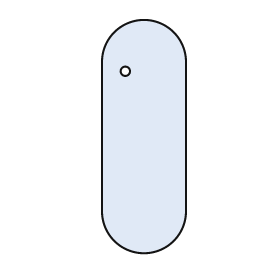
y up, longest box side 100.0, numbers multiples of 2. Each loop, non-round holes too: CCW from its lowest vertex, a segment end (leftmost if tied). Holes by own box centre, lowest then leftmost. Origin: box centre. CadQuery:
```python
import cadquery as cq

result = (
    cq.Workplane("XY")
    .moveTo(-18.0, -32.0)
    .threePointArc((0.0, -50.0), (18.0, -32.0))
    .lineTo(18.0, 32.0)
    .threePointArc((0.0, 50.0), (-18.0, 32.0))
    .close()
    .moveTo(-8.0, 28.0)
    .circle(2.0)
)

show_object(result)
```